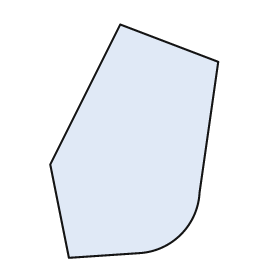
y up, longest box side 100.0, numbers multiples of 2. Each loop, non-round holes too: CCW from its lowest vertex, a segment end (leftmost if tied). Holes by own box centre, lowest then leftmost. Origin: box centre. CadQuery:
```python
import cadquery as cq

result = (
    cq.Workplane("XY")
    .moveTo(-28.0, -50.0)
    .lineTo(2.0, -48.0)
    .threePointArc((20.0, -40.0), (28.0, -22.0))
    .lineTo(36.0, 34.0)
    .lineTo(-6.0, 50.0)
    .lineTo(-36.0, -10.0)
    .close()
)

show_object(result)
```